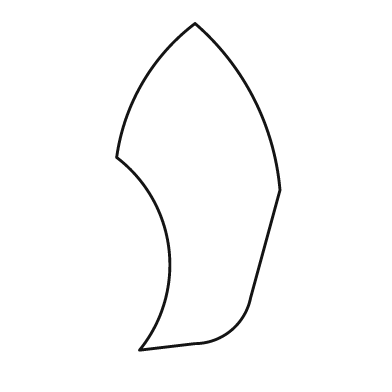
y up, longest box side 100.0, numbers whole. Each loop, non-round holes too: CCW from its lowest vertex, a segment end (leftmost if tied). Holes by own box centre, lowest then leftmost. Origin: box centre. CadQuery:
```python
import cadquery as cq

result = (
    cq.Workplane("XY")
    .moveTo(-18.0, -50.0)
    .lineTo(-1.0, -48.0)
    .threePointArc((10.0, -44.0), (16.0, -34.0))
    .lineTo(25.0, -1.0)
    .threePointArc((17.0, 27.0), (-1.0, 50.0))
    .threePointArc((-17.0, 32.0), (-25.0, 9.0))
    .threePointArc((-9.0, -19.0), (-18.0, -50.0))
    .close()
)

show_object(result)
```